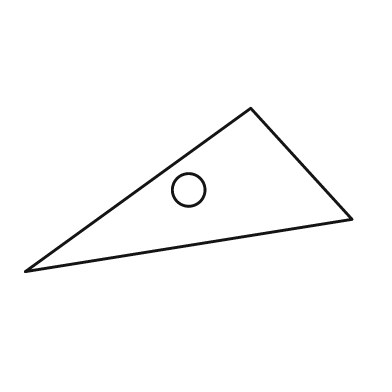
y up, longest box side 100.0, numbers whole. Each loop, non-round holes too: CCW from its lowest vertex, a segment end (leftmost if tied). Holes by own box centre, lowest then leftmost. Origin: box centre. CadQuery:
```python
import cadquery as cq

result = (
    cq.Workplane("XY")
    .moveTo(-50.0, -25.0)
    .lineTo(50.0, -9.0)
    .lineTo(19.0, 25.0)
    .close()
    .moveTo(0.0, 0.0)
    .circle(5.0)
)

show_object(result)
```